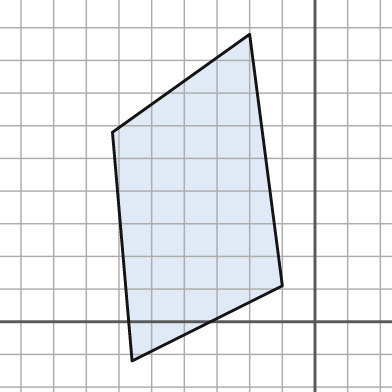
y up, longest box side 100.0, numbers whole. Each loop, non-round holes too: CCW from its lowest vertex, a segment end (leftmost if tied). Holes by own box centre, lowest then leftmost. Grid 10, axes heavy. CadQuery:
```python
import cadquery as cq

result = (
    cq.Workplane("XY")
    .moveTo(-56.0, -12.0)
    .lineTo(-10.0, 11.0)
    .lineTo(-20.0, 88.0)
    .lineTo(-62.0, 58.0)
    .close()
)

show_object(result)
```